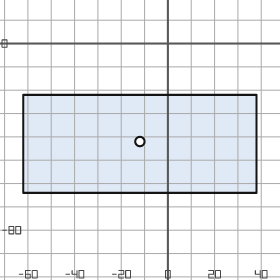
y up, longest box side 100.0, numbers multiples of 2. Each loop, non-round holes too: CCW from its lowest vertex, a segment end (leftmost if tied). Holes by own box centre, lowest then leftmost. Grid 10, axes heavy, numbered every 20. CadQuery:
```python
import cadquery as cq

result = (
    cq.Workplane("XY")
    .moveTo(-62.0, -64.0)
    .lineTo(38.0, -64.0)
    .lineTo(38.0, -22.0)
    .lineTo(-62.0, -22.0)
    .close()
    .moveTo(-12.0, -42.0)
    .circle(2.0)
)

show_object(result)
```